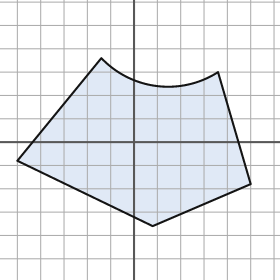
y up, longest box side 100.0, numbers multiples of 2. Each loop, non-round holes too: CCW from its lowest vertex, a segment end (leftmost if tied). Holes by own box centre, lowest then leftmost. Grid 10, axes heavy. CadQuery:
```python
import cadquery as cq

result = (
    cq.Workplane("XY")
    .moveTo(8.0, -36.0)
    .lineTo(50.0, -18.0)
    .lineTo(36.0, 30.0)
    .threePointArc((10.0, 24.0), (-14.0, 36.0))
    .lineTo(-50.0, -8.0)
    .close()
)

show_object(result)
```